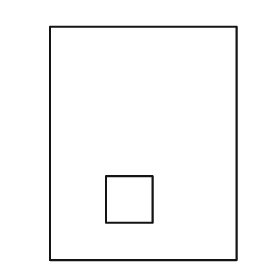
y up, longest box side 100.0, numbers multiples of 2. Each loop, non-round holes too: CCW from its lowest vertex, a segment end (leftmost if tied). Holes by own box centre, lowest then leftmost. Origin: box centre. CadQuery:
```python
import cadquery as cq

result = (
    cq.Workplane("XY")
    .moveTo(-40.0, -50.0)
    .lineTo(40.0, -50.0)
    .lineTo(40.0, 50.0)
    .lineTo(-40.0, 50.0)
    .close()
    .moveTo(-16.0, -34.0)
    .lineTo(4.0, -34.0)
    .lineTo(4.0, -14.0)
    .lineTo(-16.0, -14.0)
    .close()
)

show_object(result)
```